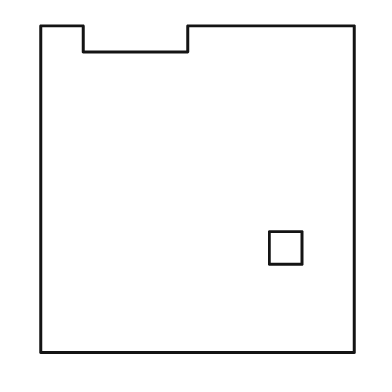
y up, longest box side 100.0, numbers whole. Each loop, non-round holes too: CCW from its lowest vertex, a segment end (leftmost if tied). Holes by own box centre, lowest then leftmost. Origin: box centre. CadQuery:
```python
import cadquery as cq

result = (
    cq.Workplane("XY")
    .moveTo(-48.0, -50.0)
    .lineTo(48.0, -50.0)
    .lineTo(48.0, 50.0)
    .lineTo(-3.0, 50.0)
    .lineTo(-3.0, 42.0)
    .lineTo(-35.0, 42.0)
    .lineTo(-35.0, 50.0)
    .lineTo(-48.0, 50.0)
    .close()
    .moveTo(22.0, -23.0)
    .lineTo(32.0, -23.0)
    .lineTo(32.0, -13.0)
    .lineTo(22.0, -13.0)
    .close()
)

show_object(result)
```